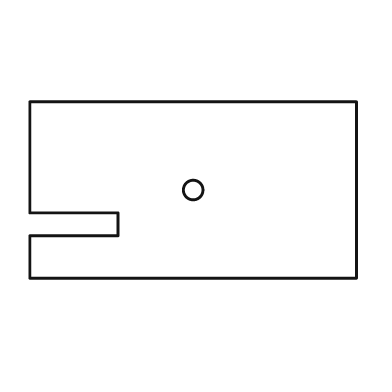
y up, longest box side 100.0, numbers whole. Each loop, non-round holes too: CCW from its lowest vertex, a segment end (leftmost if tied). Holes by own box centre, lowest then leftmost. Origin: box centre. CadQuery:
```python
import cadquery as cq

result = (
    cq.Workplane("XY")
    .moveTo(-50.0, -27.0)
    .lineTo(50.0, -27.0)
    .lineTo(50.0, 27.0)
    .lineTo(-50.0, 27.0)
    .lineTo(-50.0, -7.0)
    .lineTo(-23.0, -7.0)
    .lineTo(-23.0, -14.0)
    .lineTo(-50.0, -14.0)
    .close()
    .moveTo(0.0, 0.0)
    .circle(3.0)
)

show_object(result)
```